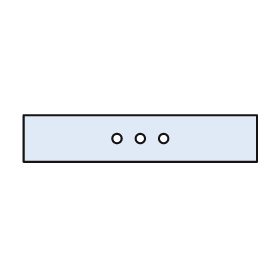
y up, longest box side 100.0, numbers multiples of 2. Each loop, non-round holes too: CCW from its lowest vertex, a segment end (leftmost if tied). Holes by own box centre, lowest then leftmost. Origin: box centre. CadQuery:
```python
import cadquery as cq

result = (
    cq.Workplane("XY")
    .moveTo(-50.0, -10.0)
    .lineTo(50.0, -10.0)
    .lineTo(50.0, 10.0)
    .lineTo(-50.0, 10.0)
    .close()
    .moveTo(-10.0, 0.0)
    .circle(2.0)
    .moveTo(0.0, 0.0)
    .circle(2.0)
    .moveTo(10.0, 0.0)
    .circle(2.0)
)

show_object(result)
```